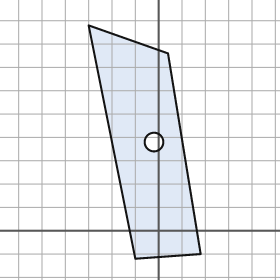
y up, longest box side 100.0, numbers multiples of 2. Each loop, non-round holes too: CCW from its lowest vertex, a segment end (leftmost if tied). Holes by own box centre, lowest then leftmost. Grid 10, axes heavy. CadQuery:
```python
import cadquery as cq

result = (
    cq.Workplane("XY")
    .moveTo(-10.0, -12.0)
    .lineTo(18.0, -10.0)
    .lineTo(4.0, 76.0)
    .lineTo(-30.0, 88.0)
    .close()
    .moveTo(-2.0, 38.0)
    .circle(4.0)
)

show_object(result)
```